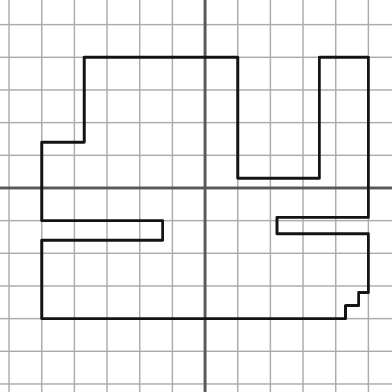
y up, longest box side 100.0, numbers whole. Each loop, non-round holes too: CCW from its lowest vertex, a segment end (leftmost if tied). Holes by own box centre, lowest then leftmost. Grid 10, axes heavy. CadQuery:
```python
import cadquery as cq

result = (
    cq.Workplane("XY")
    .moveTo(-50.0, -40.0)
    .lineTo(43.0, -40.0)
    .lineTo(43.0, -36.0)
    .lineTo(47.0, -36.0)
    .lineTo(47.0, -32.0)
    .lineTo(50.0, -32.0)
    .lineTo(50.0, -14.0)
    .lineTo(22.0, -14.0)
    .lineTo(22.0, -9.0)
    .lineTo(50.0, -9.0)
    .lineTo(50.0, 40.0)
    .lineTo(35.0, 40.0)
    .lineTo(35.0, 3.0)
    .lineTo(10.0, 3.0)
    .lineTo(10.0, 40.0)
    .lineTo(-37.0, 40.0)
    .lineTo(-37.0, 14.0)
    .lineTo(-50.0, 14.0)
    .lineTo(-50.0, -10.0)
    .lineTo(-13.0, -10.0)
    .lineTo(-13.0, -16.0)
    .lineTo(-50.0, -16.0)
    .close()
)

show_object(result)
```